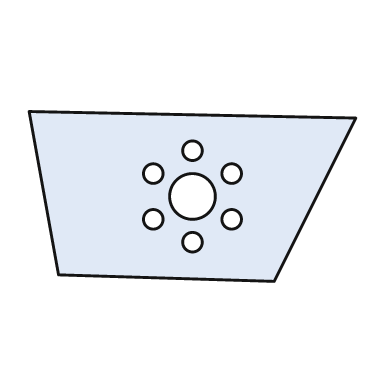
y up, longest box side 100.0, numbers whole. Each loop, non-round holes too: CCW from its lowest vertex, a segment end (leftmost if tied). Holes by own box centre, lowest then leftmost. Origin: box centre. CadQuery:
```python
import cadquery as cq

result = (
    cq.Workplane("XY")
    .moveTo(25.0, -26.0)
    .lineTo(50.0, 24.0)
    .lineTo(-50.0, 26.0)
    .lineTo(-41.0, -24.0)
    .close()
    .moveTo(0.0, -14.0)
    .circle(3.0)
    .moveTo(-12.0, -7.0)
    .circle(3.0)
    .moveTo(12.0, -7.0)
    .circle(3.0)
    .moveTo(0.0, 0.0)
    .circle(7.0)
    .moveTo(-12.0, 7.0)
    .circle(3.0)
    .moveTo(12.0, 7.0)
    .circle(3.0)
    .moveTo(0.0, 14.0)
    .circle(3.0)
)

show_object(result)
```